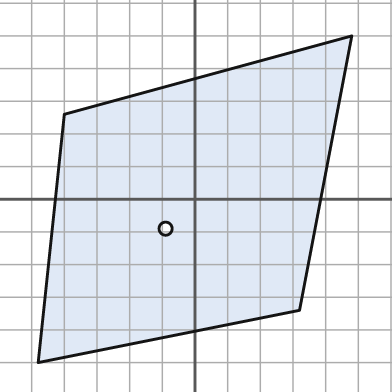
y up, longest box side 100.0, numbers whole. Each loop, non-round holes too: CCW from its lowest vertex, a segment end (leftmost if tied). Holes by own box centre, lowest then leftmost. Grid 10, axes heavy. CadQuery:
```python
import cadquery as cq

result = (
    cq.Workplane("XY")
    .moveTo(-48.0, -50.0)
    .lineTo(32.0, -34.0)
    .lineTo(48.0, 50.0)
    .lineTo(-40.0, 26.0)
    .close()
    .moveTo(-9.0, -9.0)
    .circle(2.0)
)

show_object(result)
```